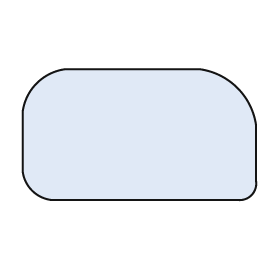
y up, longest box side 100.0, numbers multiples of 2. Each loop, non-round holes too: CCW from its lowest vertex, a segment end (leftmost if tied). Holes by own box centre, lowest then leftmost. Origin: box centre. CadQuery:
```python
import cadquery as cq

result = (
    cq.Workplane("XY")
    .moveTo(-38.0, -28.0)
    .lineTo(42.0, -28.0)
    .threePointArc((48.0, -26.0), (50.0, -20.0))
    .lineTo(50.0, 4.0)
    .threePointArc((42.0, 20.0), (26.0, 28.0))
    .lineTo(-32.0, 28.0)
    .threePointArc((-44.0, 22.0), (-50.0, 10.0))
    .lineTo(-50.0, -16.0)
    .threePointArc((-46.0, -24.0), (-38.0, -28.0))
    .close()
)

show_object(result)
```